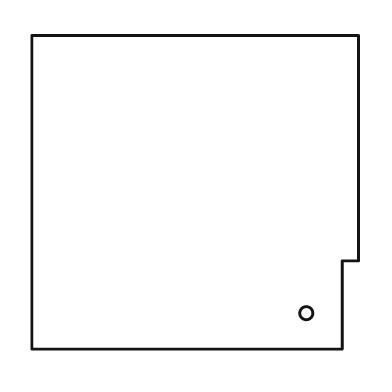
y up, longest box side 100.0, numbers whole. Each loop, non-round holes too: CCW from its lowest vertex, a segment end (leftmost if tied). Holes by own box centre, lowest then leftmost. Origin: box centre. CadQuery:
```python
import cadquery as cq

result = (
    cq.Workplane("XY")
    .moveTo(-50.0, -48.0)
    .lineTo(45.0, -48.0)
    .lineTo(45.0, -21.0)
    .lineTo(50.0, -21.0)
    .lineTo(50.0, 48.0)
    .lineTo(-50.0, 48.0)
    .close()
    .moveTo(34.0, -37.0)
    .circle(2.0)
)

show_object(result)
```